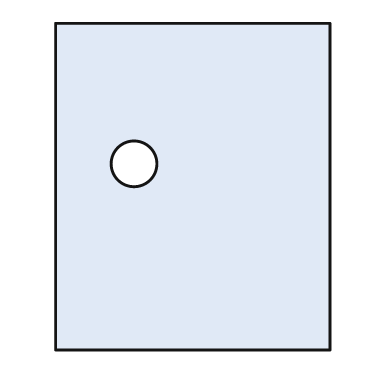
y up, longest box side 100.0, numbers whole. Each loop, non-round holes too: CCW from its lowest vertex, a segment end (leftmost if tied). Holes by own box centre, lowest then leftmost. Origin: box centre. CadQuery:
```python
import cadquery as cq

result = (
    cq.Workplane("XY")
    .moveTo(-42.0, -50.0)
    .lineTo(42.0, -50.0)
    .lineTo(42.0, 50.0)
    .lineTo(-42.0, 50.0)
    .close()
    .moveTo(-18.0, 7.0)
    .circle(7.0)
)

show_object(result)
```